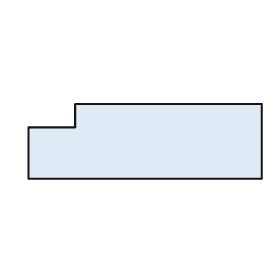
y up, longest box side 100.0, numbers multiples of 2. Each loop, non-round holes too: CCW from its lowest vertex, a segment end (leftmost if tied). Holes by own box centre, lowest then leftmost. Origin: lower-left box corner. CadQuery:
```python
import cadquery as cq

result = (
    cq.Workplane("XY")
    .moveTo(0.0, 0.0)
    .lineTo(100.0, 0.0)
    .lineTo(100.0, 32.0)
    .lineTo(20.0, 32.0)
    .lineTo(20.0, 22.0)
    .lineTo(0.0, 22.0)
    .close()
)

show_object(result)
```